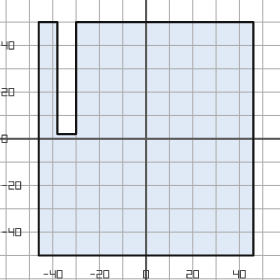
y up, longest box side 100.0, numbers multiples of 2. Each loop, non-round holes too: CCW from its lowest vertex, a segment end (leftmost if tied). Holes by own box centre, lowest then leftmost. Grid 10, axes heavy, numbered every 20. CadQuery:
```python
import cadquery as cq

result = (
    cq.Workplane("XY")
    .moveTo(-46.0, -50.0)
    .lineTo(46.0, -50.0)
    .lineTo(46.0, 50.0)
    .lineTo(-30.0, 50.0)
    .lineTo(-30.0, 2.0)
    .lineTo(-38.0, 2.0)
    .lineTo(-38.0, 50.0)
    .lineTo(-46.0, 50.0)
    .close()
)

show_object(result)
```